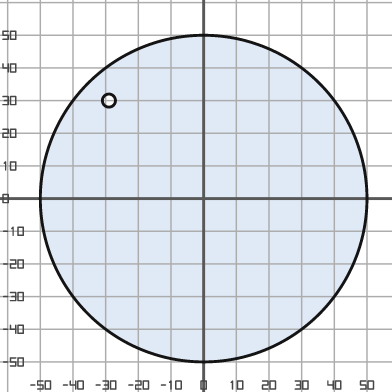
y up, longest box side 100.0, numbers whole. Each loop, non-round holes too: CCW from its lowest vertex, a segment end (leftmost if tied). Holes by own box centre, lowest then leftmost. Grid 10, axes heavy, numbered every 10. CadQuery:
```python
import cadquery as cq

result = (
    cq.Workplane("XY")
    .moveTo(0.0, 0.0)
    .circle(50.0)
    .moveTo(-29.0, 30.0)
    .circle(2.0)
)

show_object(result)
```